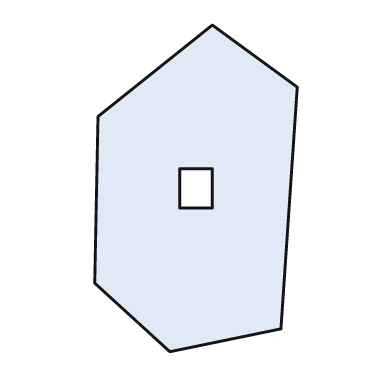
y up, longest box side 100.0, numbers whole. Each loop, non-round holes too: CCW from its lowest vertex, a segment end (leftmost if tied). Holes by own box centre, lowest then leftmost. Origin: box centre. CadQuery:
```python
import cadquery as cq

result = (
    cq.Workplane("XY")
    .moveTo(-8.0, -50.0)
    .lineTo(26.0, -43.0)
    .lineTo(31.0, 31.0)
    .lineTo(5.0, 50.0)
    .lineTo(-30.0, 22.0)
    .lineTo(-31.0, -29.0)
    .close()
    .moveTo(-5.0, -6.0)
    .lineTo(5.0, -6.0)
    .lineTo(5.0, 6.0)
    .lineTo(-5.0, 6.0)
    .close()
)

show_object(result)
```